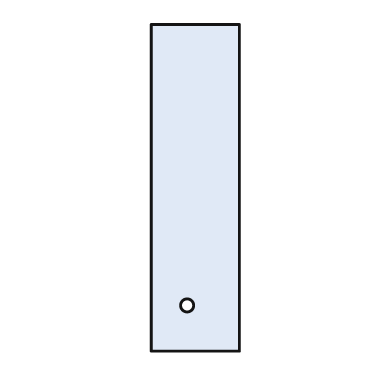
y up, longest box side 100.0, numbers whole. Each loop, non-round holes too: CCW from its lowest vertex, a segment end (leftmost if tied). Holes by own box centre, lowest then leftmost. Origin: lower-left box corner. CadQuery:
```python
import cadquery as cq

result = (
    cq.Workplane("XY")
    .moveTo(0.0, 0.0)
    .lineTo(27.0, 0.0)
    .lineTo(27.0, 100.0)
    .lineTo(0.0, 100.0)
    .close()
    .moveTo(11.0, 14.0)
    .circle(2.0)
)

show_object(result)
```